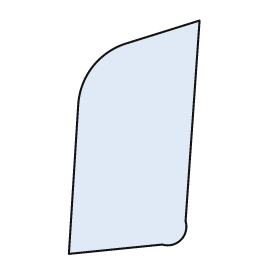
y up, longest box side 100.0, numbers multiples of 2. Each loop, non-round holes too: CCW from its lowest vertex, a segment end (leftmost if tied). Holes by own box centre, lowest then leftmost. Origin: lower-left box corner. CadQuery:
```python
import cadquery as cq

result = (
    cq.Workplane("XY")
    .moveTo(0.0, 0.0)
    .lineTo(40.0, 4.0)
    .threePointArc((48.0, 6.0), (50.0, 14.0))
    .lineTo(56.0, 100.0)
    .lineTo(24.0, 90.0)
    .threePointArc((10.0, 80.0), (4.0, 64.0))
    .close()
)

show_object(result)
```